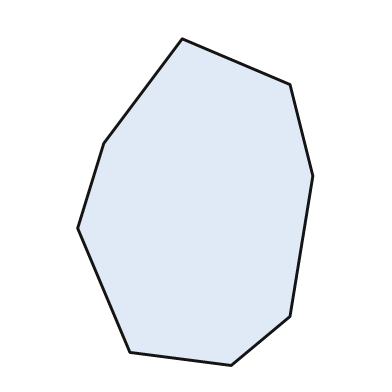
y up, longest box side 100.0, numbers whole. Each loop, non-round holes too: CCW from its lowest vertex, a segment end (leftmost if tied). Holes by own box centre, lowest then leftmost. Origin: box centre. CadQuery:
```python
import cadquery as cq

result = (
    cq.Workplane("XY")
    .moveTo(11.0, -50.0)
    .lineTo(29.0, -35.0)
    .lineTo(36.0, 8.0)
    .lineTo(29.0, 36.0)
    .lineTo(-4.0, 50.0)
    .lineTo(-28.0, 18.0)
    .lineTo(-36.0, -8.0)
    .lineTo(-20.0, -46.0)
    .close()
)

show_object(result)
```